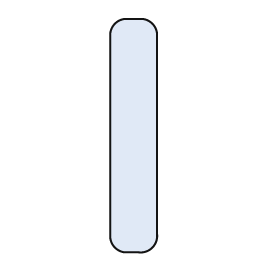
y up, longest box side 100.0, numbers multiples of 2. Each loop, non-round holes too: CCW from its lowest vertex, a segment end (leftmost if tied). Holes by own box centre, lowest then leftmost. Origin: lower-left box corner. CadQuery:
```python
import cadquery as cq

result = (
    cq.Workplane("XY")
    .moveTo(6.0, 0.0)
    .lineTo(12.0, 0.0)
    .threePointArc((18.0, 2.0), (20.0, 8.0))
    .lineTo(20.0, 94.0)
    .threePointArc((18.0, 98.0), (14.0, 100.0))
    .lineTo(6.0, 100.0)
    .threePointArc((2.0, 98.0), (0.0, 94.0))
    .lineTo(0.0, 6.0)
    .threePointArc((2.0, 2.0), (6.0, 0.0))
    .close()
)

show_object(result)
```